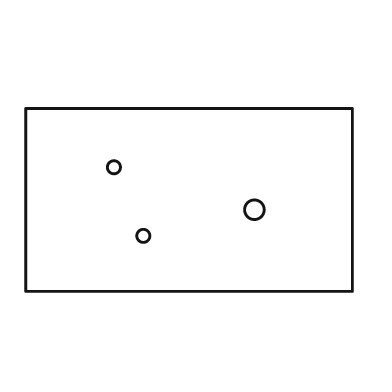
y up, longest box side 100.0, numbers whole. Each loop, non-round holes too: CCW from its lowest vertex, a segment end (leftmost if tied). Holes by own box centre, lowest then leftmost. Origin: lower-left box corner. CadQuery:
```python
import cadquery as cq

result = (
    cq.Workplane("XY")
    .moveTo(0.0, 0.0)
    .lineTo(100.0, 0.0)
    .lineTo(100.0, 56.0)
    .lineTo(0.0, 56.0)
    .close()
    .moveTo(36.0, 17.0)
    .circle(2.0)
    .moveTo(70.0, 25.0)
    .circle(3.0)
    .moveTo(27.0, 38.0)
    .circle(2.0)
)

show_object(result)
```